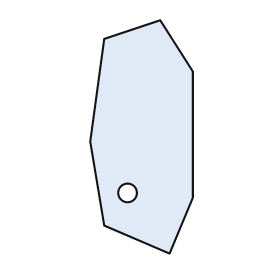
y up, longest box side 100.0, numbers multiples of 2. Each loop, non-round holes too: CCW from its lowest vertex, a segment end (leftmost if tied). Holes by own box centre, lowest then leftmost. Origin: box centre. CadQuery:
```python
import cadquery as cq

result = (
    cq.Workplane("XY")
    .moveTo(12.0, -50.0)
    .lineTo(22.0, -26.0)
    .lineTo(22.0, 28.0)
    .lineTo(8.0, 50.0)
    .lineTo(-16.0, 42.0)
    .lineTo(-22.0, -2.0)
    .lineTo(-16.0, -38.0)
    .close()
    .moveTo(-6.0, -24.0)
    .circle(4.0)
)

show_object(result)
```